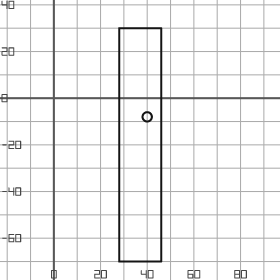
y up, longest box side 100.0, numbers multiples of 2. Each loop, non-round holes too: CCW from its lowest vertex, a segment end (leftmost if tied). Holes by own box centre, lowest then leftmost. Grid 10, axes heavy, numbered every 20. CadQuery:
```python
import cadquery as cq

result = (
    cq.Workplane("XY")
    .moveTo(28.0, -70.0)
    .lineTo(46.0, -70.0)
    .lineTo(46.0, 30.0)
    .lineTo(28.0, 30.0)
    .close()
    .moveTo(40.0, -8.0)
    .circle(2.0)
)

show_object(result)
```